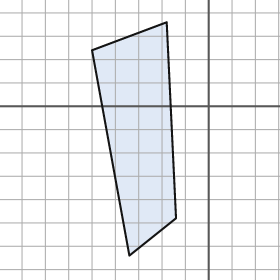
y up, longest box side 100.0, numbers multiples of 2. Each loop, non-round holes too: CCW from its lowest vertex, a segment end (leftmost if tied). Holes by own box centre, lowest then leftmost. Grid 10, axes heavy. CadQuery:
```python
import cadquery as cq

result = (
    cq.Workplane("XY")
    .moveTo(-34.0, -64.0)
    .lineTo(-14.0, -48.0)
    .lineTo(-18.0, 36.0)
    .lineTo(-50.0, 24.0)
    .close()
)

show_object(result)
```